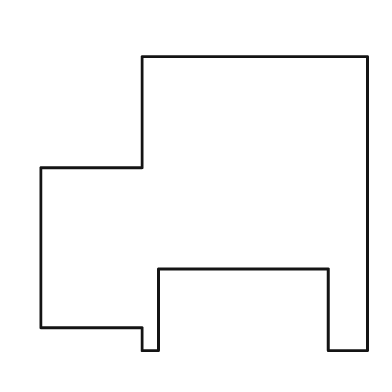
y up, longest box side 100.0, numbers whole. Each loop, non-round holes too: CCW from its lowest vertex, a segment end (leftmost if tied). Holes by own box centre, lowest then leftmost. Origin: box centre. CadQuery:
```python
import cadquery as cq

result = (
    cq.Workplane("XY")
    .moveTo(-19.0, -45.0)
    .lineTo(-14.0, -45.0)
    .lineTo(-14.0, -20.0)
    .lineTo(38.0, -20.0)
    .lineTo(38.0, -45.0)
    .lineTo(50.0, -45.0)
    .lineTo(50.0, 45.0)
    .lineTo(-19.0, 45.0)
    .lineTo(-19.0, 11.0)
    .lineTo(-50.0, 11.0)
    .lineTo(-50.0, -38.0)
    .lineTo(-19.0, -38.0)
    .close()
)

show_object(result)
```